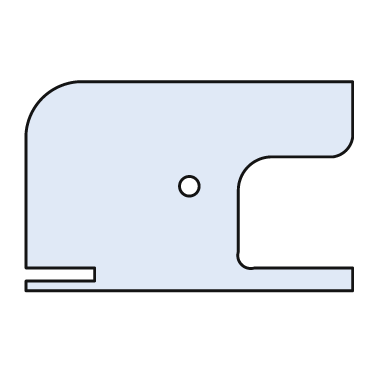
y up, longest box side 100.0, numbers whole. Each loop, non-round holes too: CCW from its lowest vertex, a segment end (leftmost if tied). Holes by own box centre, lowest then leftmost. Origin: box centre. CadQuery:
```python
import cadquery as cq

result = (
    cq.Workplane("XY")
    .moveTo(-50.0, -32.0)
    .lineTo(50.0, -32.0)
    .lineTo(50.0, -25.0)
    .lineTo(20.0, -25.0)
    .threePointArc((16.0, -24.0), (15.0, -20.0))
    .lineTo(15.0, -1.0)
    .threePointArc((18.0, 6.0), (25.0, 9.0))
    .lineTo(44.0, 9.0)
    .threePointArc((48.0, 11.0), (50.0, 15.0))
    .lineTo(50.0, 32.0)
    .lineTo(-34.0, 32.0)
    .threePointArc((-45.0, 27.0), (-50.0, 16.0))
    .lineTo(-50.0, -25.0)
    .lineTo(-29.0, -25.0)
    .lineTo(-29.0, -29.0)
    .lineTo(-50.0, -29.0)
    .close()
    .moveTo(0.0, 0.0)
    .circle(3.0)
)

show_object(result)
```